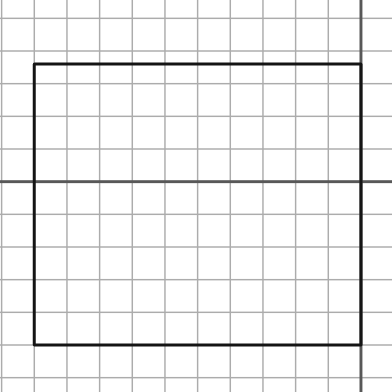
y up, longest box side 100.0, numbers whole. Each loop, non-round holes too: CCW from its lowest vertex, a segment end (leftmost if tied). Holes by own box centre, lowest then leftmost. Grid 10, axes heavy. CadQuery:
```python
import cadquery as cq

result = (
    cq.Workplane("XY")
    .moveTo(-100.0, -50.0)
    .lineTo(0.0, -50.0)
    .lineTo(0.0, 36.0)
    .lineTo(-100.0, 36.0)
    .close()
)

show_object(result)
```